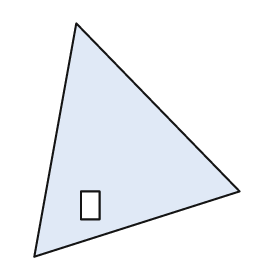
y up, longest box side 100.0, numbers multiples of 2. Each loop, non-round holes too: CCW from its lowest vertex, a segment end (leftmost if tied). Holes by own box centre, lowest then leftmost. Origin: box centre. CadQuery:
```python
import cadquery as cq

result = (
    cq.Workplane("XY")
    .moveTo(-44.0, -50.0)
    .lineTo(44.0, -22.0)
    .lineTo(-26.0, 50.0)
    .close()
    .moveTo(-24.0, -34.0)
    .lineTo(-16.0, -34.0)
    .lineTo(-16.0, -22.0)
    .lineTo(-24.0, -22.0)
    .close()
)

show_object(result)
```